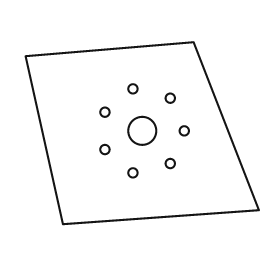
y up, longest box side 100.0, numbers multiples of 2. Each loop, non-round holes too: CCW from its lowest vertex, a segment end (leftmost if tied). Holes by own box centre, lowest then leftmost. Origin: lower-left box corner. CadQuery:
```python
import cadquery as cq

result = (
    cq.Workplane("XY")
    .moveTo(16.0, 0.0)
    .lineTo(100.0, 6.0)
    .lineTo(72.0, 78.0)
    .lineTo(0.0, 72.0)
    .close()
    .moveTo(46.0, 22.0)
    .circle(2.0)
    .moveTo(62.0, 26.0)
    .circle(2.0)
    .moveTo(34.0, 32.0)
    .circle(2.0)
    .moveTo(50.0, 40.0)
    .circle(6.0)
    .moveTo(68.0, 40.0)
    .circle(2.0)
    .moveTo(34.0, 48.0)
    .circle(2.0)
    .moveTo(62.0, 54.0)
    .circle(2.0)
    .moveTo(46.0, 58.0)
    .circle(2.0)
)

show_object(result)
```